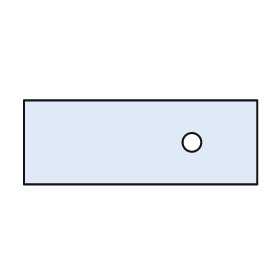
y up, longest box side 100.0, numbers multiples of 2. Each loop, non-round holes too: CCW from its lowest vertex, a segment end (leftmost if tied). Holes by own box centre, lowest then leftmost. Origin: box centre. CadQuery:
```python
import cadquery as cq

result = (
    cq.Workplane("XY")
    .moveTo(-50.0, -18.0)
    .lineTo(50.0, -18.0)
    .lineTo(50.0, 18.0)
    .lineTo(-50.0, 18.0)
    .close()
    .moveTo(22.0, 0.0)
    .circle(4.0)
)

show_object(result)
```